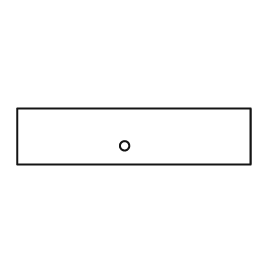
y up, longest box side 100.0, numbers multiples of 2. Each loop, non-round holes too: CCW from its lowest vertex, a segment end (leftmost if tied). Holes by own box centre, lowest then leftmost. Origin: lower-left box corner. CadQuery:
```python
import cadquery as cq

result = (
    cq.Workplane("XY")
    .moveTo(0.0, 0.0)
    .lineTo(100.0, 0.0)
    .lineTo(100.0, 24.0)
    .lineTo(0.0, 24.0)
    .close()
    .moveTo(46.0, 8.0)
    .circle(2.0)
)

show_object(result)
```